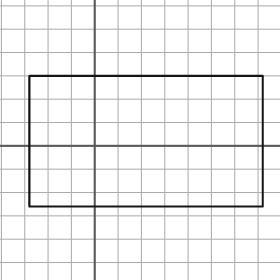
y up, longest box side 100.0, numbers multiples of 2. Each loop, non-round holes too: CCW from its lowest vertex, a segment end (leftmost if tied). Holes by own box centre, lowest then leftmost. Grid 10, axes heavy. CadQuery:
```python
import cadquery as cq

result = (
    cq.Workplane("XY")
    .moveTo(-28.0, -26.0)
    .lineTo(72.0, -26.0)
    .lineTo(72.0, 30.0)
    .lineTo(-28.0, 30.0)
    .close()
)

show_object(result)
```